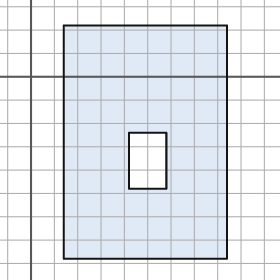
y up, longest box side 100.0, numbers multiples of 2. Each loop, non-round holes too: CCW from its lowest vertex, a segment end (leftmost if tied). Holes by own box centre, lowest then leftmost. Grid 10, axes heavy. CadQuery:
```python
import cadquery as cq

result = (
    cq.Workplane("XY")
    .moveTo(14.0, -78.0)
    .lineTo(84.0, -78.0)
    .lineTo(84.0, 22.0)
    .lineTo(14.0, 22.0)
    .close()
    .moveTo(42.0, -48.0)
    .lineTo(58.0, -48.0)
    .lineTo(58.0, -24.0)
    .lineTo(42.0, -24.0)
    .close()
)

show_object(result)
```